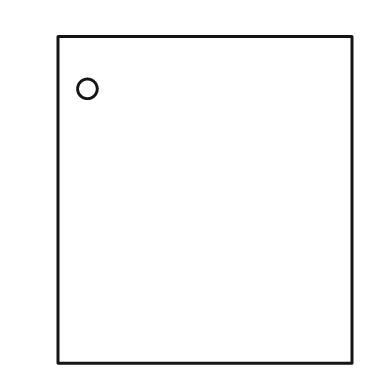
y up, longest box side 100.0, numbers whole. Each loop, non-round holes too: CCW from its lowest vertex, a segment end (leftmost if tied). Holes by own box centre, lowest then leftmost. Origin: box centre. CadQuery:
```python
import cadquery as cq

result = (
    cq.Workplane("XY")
    .moveTo(-45.0, -50.0)
    .lineTo(45.0, -50.0)
    .lineTo(45.0, 50.0)
    .lineTo(-45.0, 50.0)
    .close()
    .moveTo(-36.0, 34.0)
    .circle(3.0)
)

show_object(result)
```